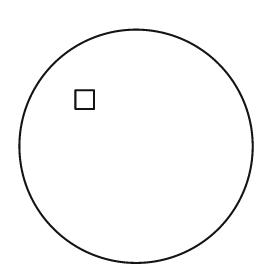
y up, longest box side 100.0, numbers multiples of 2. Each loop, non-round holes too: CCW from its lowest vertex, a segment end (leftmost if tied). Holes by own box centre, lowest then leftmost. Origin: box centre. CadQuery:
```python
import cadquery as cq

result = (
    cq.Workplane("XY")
    .moveTo(0.0, 0.0)
    .circle(50.0)
    .moveTo(-26.0, 16.0)
    .lineTo(-18.0, 16.0)
    .lineTo(-18.0, 24.0)
    .lineTo(-26.0, 24.0)
    .close()
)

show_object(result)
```